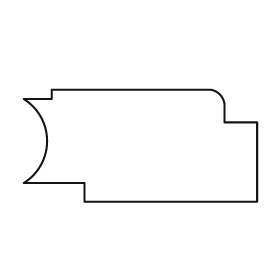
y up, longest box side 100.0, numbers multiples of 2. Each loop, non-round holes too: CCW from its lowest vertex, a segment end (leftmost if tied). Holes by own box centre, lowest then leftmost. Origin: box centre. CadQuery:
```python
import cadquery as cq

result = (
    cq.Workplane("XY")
    .moveTo(-24.0, -24.0)
    .lineTo(50.0, -24.0)
    .lineTo(50.0, 10.0)
    .lineTo(36.0, 10.0)
    .lineTo(36.0, 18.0)
    .threePointArc((34.0, 22.0), (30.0, 24.0))
    .lineTo(-38.0, 24.0)
    .lineTo(-38.0, 20.0)
    .lineTo(-50.0, 20.0)
    .threePointArc((-40.0, 2.0), (-50.0, -16.0))
    .lineTo(-24.0, -16.0)
    .close()
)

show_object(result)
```